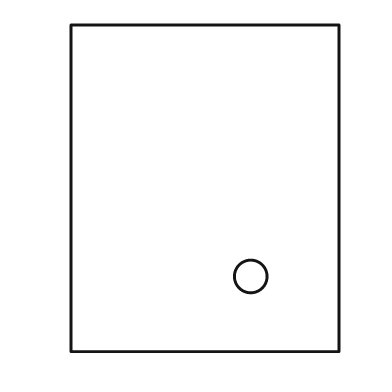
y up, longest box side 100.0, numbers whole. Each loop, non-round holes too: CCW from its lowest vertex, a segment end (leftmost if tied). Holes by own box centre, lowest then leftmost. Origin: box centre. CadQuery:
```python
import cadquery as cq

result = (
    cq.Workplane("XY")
    .moveTo(-41.0, -50.0)
    .lineTo(41.0, -50.0)
    .lineTo(41.0, 50.0)
    .lineTo(-41.0, 50.0)
    .close()
    .moveTo(14.0, -27.0)
    .circle(5.0)
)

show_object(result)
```